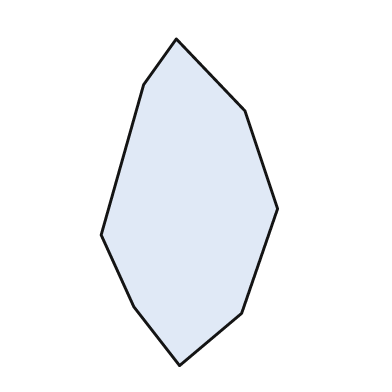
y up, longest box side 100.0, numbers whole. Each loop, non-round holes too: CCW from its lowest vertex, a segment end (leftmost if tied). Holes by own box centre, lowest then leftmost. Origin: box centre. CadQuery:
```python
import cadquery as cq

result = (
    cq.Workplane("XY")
    .moveTo(-3.0, -50.0)
    .lineTo(16.0, -34.0)
    .lineTo(27.0, -2.0)
    .lineTo(17.0, 28.0)
    .lineTo(-4.0, 50.0)
    .lineTo(-14.0, 36.0)
    .lineTo(-27.0, -10.0)
    .lineTo(-17.0, -32.0)
    .close()
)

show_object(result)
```